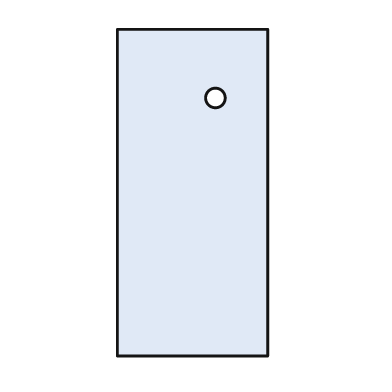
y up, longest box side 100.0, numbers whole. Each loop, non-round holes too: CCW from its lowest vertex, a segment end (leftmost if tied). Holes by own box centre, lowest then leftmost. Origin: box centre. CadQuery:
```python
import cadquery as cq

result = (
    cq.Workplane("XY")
    .moveTo(-23.0, -50.0)
    .lineTo(23.0, -50.0)
    .lineTo(23.0, 50.0)
    .lineTo(-23.0, 50.0)
    .close()
    .moveTo(7.0, 29.0)
    .circle(3.0)
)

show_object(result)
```